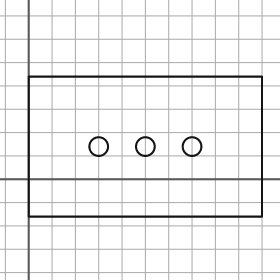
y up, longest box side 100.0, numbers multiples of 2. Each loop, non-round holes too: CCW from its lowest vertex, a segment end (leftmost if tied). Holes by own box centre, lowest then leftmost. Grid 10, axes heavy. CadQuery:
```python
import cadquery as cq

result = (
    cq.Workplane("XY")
    .moveTo(0.0, -16.0)
    .lineTo(100.0, -16.0)
    .lineTo(100.0, 44.0)
    .lineTo(0.0, 44.0)
    .close()
    .moveTo(30.0, 14.0)
    .circle(4.0)
    .moveTo(50.0, 14.0)
    .circle(4.0)
    .moveTo(70.0, 14.0)
    .circle(4.0)
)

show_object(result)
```